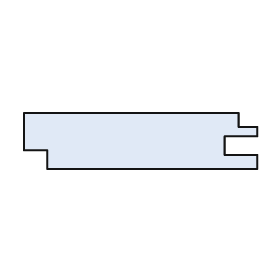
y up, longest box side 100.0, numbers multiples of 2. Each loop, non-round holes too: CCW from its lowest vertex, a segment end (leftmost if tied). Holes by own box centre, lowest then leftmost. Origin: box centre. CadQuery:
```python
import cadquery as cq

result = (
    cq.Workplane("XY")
    .moveTo(-40.0, -12.0)
    .lineTo(50.0, -12.0)
    .lineTo(50.0, -6.0)
    .lineTo(36.0, -6.0)
    .lineTo(36.0, 2.0)
    .lineTo(50.0, 2.0)
    .lineTo(50.0, 6.0)
    .lineTo(42.0, 6.0)
    .lineTo(42.0, 12.0)
    .lineTo(-50.0, 12.0)
    .lineTo(-50.0, -4.0)
    .lineTo(-40.0, -4.0)
    .close()
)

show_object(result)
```